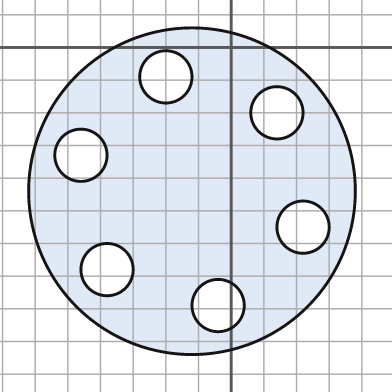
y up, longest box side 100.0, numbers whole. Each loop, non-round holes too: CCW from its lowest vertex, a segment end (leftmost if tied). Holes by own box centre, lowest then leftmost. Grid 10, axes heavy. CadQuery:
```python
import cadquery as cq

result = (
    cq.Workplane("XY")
    .moveTo(-12.0, -44.0)
    .circle(50.0)
    .moveTo(-4.0, -79.0)
    .circle(8.0)
    .moveTo(-38.0, -68.0)
    .circle(8.0)
    .moveTo(22.0, -55.0)
    .circle(8.0)
    .moveTo(-46.0, -33.0)
    .circle(8.0)
    .moveTo(14.0, -20.0)
    .circle(8.0)
    .moveTo(-20.0, -9.0)
    .circle(8.0)
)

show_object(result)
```